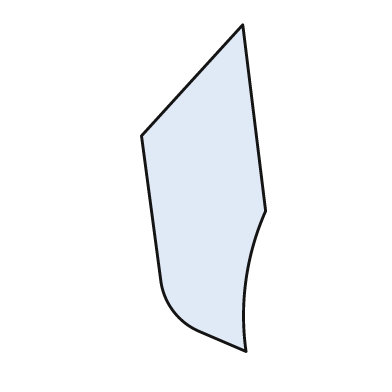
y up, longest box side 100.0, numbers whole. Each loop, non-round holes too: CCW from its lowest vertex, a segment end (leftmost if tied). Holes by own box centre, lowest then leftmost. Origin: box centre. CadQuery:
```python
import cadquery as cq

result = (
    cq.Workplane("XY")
    .moveTo(13.0, -50.0)
    .threePointArc((13.0, -28.0), (19.0, -7.0))
    .lineTo(12.0, 50.0)
    .lineTo(-19.0, 16.0)
    .lineTo(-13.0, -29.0)
    .threePointArc((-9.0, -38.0), (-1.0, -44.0))
    .close()
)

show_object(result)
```